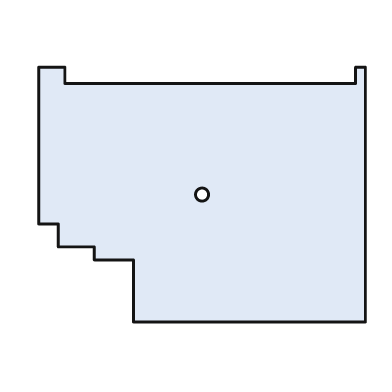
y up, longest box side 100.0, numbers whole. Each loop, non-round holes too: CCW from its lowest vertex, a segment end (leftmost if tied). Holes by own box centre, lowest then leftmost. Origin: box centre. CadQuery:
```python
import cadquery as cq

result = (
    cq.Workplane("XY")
    .moveTo(-21.0, -39.0)
    .lineTo(50.0, -39.0)
    .lineTo(50.0, 39.0)
    .lineTo(47.0, 39.0)
    .lineTo(47.0, 34.0)
    .lineTo(-42.0, 34.0)
    .lineTo(-42.0, 39.0)
    .lineTo(-50.0, 39.0)
    .lineTo(-50.0, -9.0)
    .lineTo(-44.0, -9.0)
    .lineTo(-44.0, -16.0)
    .lineTo(-33.0, -16.0)
    .lineTo(-33.0, -20.0)
    .lineTo(-21.0, -20.0)
    .close()
    .moveTo(0.0, 0.0)
    .circle(2.0)
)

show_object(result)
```